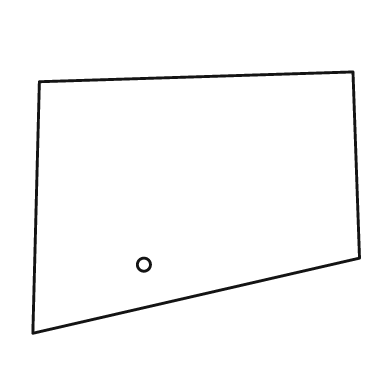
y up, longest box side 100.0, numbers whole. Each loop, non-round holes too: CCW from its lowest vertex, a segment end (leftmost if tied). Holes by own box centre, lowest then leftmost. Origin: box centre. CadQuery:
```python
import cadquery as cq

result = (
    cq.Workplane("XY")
    .moveTo(-50.0, -40.0)
    .lineTo(50.0, -17.0)
    .lineTo(48.0, 40.0)
    .lineTo(-48.0, 37.0)
    .close()
    .moveTo(-16.0, -19.0)
    .circle(2.0)
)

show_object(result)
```